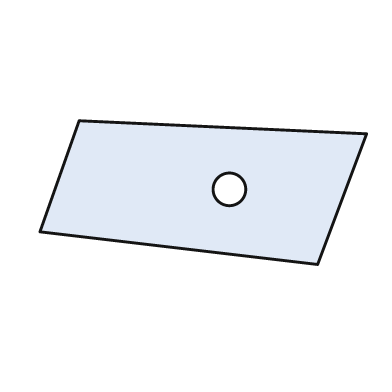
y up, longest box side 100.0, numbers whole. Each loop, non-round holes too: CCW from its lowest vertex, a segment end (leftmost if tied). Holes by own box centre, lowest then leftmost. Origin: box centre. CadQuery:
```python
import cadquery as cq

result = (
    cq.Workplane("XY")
    .moveTo(35.0, -22.0)
    .lineTo(50.0, 18.0)
    .lineTo(-38.0, 22.0)
    .lineTo(-50.0, -12.0)
    .close()
    .moveTo(8.0, 1.0)
    .circle(5.0)
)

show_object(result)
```